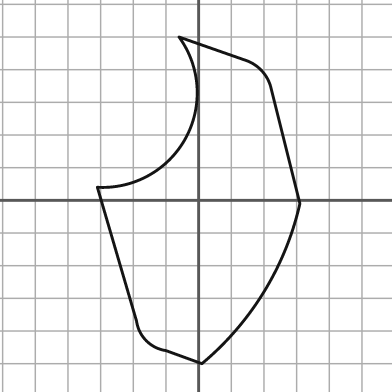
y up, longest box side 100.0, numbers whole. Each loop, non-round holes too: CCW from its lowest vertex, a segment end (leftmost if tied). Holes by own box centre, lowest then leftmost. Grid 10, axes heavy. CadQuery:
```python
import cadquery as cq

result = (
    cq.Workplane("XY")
    .moveTo(1.0, -50.0)
    .threePointArc((20.0, -28.0), (31.0, -1.0))
    .lineTo(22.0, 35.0)
    .threePointArc((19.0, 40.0), (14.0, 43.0))
    .lineTo(-6.0, 50.0)
    .threePointArc((-4.0, 19.0), (-31.0, 4.0))
    .lineTo(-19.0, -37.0)
    .threePointArc((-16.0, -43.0), (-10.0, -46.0))
    .close()
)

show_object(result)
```